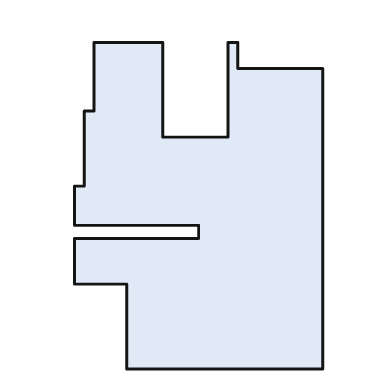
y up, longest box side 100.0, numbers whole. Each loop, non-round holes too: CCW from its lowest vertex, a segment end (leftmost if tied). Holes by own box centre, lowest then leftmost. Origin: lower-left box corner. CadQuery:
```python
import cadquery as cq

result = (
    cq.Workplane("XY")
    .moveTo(16.0, 0.0)
    .lineTo(76.0, 0.0)
    .lineTo(76.0, 92.0)
    .lineTo(50.0, 92.0)
    .lineTo(50.0, 100.0)
    .lineTo(47.0, 100.0)
    .lineTo(47.0, 71.0)
    .lineTo(27.0, 71.0)
    .lineTo(27.0, 100.0)
    .lineTo(6.0, 100.0)
    .lineTo(6.0, 79.0)
    .lineTo(3.0, 79.0)
    .lineTo(3.0, 56.0)
    .lineTo(0.0, 56.0)
    .lineTo(0.0, 44.0)
    .lineTo(38.0, 44.0)
    .lineTo(38.0, 40.0)
    .lineTo(0.0, 40.0)
    .lineTo(0.0, 26.0)
    .lineTo(16.0, 26.0)
    .close()
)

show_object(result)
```